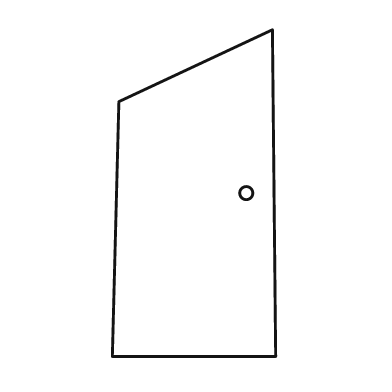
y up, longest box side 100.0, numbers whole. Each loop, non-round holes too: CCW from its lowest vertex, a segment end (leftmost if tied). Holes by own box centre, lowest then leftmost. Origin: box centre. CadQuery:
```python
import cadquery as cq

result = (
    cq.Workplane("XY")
    .moveTo(-25.0, -50.0)
    .lineTo(25.0, -50.0)
    .lineTo(24.0, 50.0)
    .lineTo(-23.0, 28.0)
    .close()
    .moveTo(16.0, 0.0)
    .circle(2.0)
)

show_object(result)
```